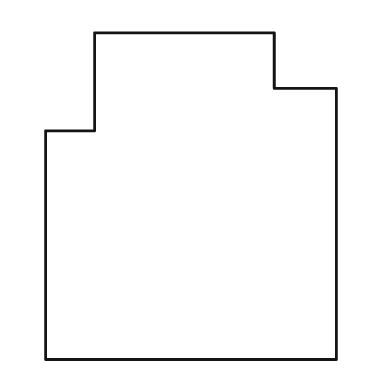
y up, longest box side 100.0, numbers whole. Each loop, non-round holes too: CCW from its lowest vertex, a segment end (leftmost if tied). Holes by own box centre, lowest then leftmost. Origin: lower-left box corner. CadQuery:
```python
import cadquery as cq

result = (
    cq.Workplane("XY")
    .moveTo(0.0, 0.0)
    .lineTo(89.0, 0.0)
    .lineTo(89.0, 83.0)
    .lineTo(70.0, 83.0)
    .lineTo(70.0, 100.0)
    .lineTo(15.0, 100.0)
    .lineTo(15.0, 70.0)
    .lineTo(0.0, 70.0)
    .close()
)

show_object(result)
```